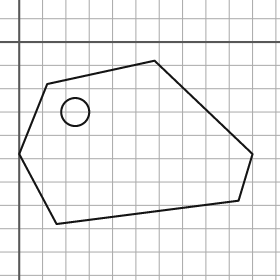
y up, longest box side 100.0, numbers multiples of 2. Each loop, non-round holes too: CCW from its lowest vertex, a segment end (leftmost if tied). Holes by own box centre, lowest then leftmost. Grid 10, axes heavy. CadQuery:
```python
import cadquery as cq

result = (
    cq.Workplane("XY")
    .moveTo(16.0, -78.0)
    .lineTo(94.0, -68.0)
    .lineTo(100.0, -48.0)
    .lineTo(58.0, -8.0)
    .lineTo(12.0, -18.0)
    .lineTo(0.0, -48.0)
    .close()
    .moveTo(24.0, -30.0)
    .circle(6.0)
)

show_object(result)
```